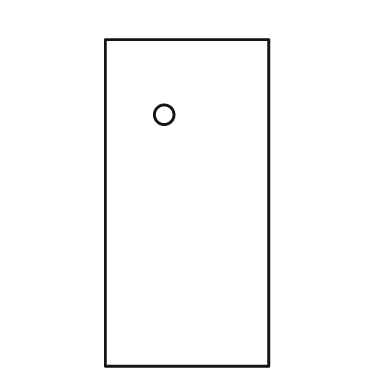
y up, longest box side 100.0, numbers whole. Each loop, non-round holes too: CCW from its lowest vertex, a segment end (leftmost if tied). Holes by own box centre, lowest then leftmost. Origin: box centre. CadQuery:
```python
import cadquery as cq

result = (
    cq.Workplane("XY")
    .moveTo(-25.0, -50.0)
    .lineTo(25.0, -50.0)
    .lineTo(25.0, 50.0)
    .lineTo(-25.0, 50.0)
    .close()
    .moveTo(-7.0, 27.0)
    .circle(3.0)
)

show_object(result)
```